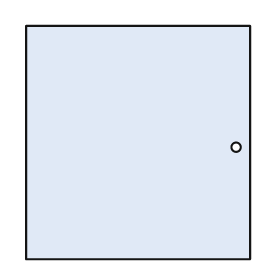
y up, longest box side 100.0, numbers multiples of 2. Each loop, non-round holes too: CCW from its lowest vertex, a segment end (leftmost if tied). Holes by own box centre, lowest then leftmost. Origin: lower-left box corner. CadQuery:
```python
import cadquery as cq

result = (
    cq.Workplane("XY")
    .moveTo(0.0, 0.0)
    .lineTo(96.0, 0.0)
    .lineTo(96.0, 100.0)
    .lineTo(0.0, 100.0)
    .close()
    .moveTo(90.0, 48.0)
    .circle(2.0)
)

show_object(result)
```